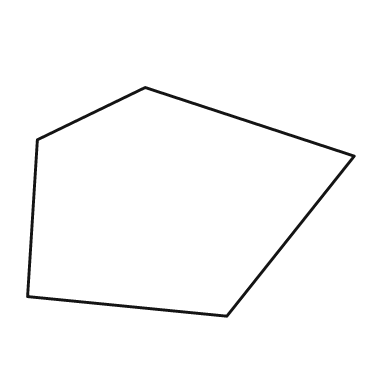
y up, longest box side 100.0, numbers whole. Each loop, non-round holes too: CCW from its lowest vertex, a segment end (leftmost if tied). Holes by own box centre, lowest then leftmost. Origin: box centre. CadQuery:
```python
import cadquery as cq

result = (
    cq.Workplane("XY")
    .moveTo(11.0, -35.0)
    .lineTo(50.0, 14.0)
    .lineTo(-14.0, 35.0)
    .lineTo(-47.0, 19.0)
    .lineTo(-50.0, -29.0)
    .close()
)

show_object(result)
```